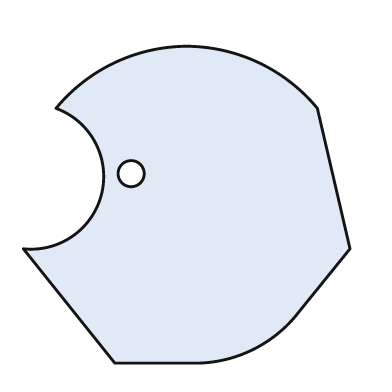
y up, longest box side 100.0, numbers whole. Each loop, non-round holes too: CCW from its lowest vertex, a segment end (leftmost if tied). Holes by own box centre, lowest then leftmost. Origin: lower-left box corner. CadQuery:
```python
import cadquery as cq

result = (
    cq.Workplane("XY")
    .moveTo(28.0, 0.0)
    .lineTo(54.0, 0.0)
    .threePointArc((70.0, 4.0), (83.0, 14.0))
    .lineTo(100.0, 35.0)
    .lineTo(90.0, 78.0)
    .threePointArc((72.0, 92.0), (50.0, 97.0))
    .threePointArc((28.0, 92.0), (10.0, 78.0))
    .threePointArc((24.0, 52.0), (0.0, 35.0))
    .close()
    .moveTo(33.0, 58.0)
    .circle(4.0)
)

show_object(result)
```